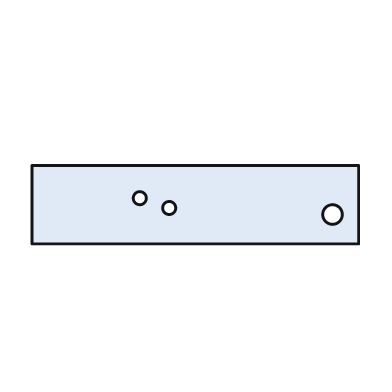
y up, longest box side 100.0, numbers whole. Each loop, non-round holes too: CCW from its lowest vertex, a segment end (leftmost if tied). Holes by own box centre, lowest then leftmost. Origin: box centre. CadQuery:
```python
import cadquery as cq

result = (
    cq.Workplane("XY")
    .moveTo(-50.0, -12.0)
    .lineTo(50.0, -12.0)
    .lineTo(50.0, 12.0)
    .lineTo(-50.0, 12.0)
    .close()
    .moveTo(42.0, -3.0)
    .circle(3.0)
    .moveTo(-8.0, -1.0)
    .circle(2.0)
    .moveTo(-17.0, 2.0)
    .circle(2.0)
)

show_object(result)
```